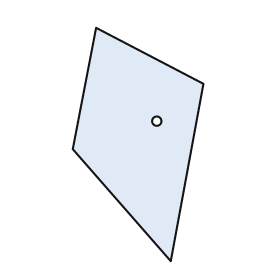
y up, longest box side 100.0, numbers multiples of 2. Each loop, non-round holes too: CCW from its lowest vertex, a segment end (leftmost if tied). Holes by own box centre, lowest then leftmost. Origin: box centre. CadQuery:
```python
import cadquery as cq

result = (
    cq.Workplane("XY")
    .moveTo(14.0, -50.0)
    .lineTo(28.0, 26.0)
    .lineTo(-18.0, 50.0)
    .lineTo(-28.0, -2.0)
    .close()
    .moveTo(8.0, 10.0)
    .circle(2.0)
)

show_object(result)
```